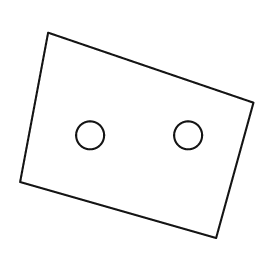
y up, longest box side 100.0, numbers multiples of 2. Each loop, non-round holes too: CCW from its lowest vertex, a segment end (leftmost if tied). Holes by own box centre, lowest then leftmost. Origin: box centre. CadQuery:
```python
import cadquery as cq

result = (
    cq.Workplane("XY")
    .moveTo(34.0, -44.0)
    .lineTo(50.0, 14.0)
    .lineTo(-38.0, 44.0)
    .lineTo(-50.0, -20.0)
    .close()
    .moveTo(-20.0, 0.0)
    .circle(6.0)
    .moveTo(22.0, 0.0)
    .circle(6.0)
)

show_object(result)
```